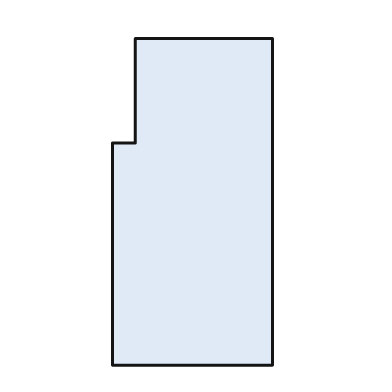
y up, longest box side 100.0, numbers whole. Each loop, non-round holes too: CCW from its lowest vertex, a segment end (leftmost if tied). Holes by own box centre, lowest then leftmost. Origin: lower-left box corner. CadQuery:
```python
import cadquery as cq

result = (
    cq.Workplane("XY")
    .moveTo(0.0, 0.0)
    .lineTo(49.0, 0.0)
    .lineTo(49.0, 100.0)
    .lineTo(7.0, 100.0)
    .lineTo(7.0, 68.0)
    .lineTo(0.0, 68.0)
    .close()
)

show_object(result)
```